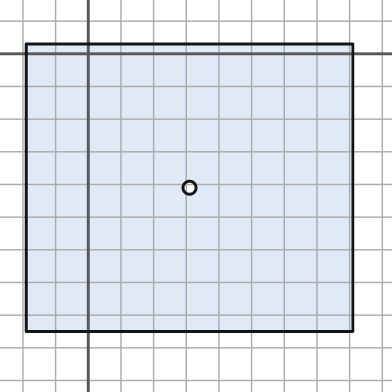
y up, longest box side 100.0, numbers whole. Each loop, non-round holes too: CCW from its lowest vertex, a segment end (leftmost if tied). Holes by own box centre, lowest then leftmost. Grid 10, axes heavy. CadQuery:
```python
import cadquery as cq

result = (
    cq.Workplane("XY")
    .moveTo(-19.0, -85.0)
    .lineTo(81.0, -85.0)
    .lineTo(81.0, 3.0)
    .lineTo(-19.0, 3.0)
    .close()
    .moveTo(31.0, -41.0)
    .circle(2.0)
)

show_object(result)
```